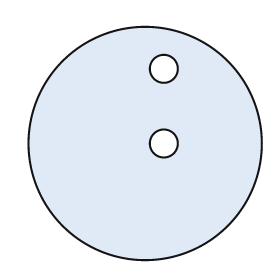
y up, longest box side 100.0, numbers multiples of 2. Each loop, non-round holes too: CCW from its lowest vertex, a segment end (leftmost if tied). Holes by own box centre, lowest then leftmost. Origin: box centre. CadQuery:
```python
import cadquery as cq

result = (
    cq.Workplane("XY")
    .moveTo(0.0, 0.0)
    .circle(50.0)
    .moveTo(8.0, 0.0)
    .circle(6.0)
    .moveTo(8.0, 32.0)
    .circle(6.0)
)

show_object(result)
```